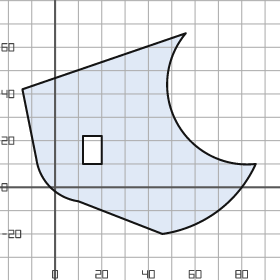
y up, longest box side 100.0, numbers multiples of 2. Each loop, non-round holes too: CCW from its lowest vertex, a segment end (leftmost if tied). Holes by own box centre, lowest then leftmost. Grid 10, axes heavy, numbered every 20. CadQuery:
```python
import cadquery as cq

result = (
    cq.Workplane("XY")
    .moveTo(46.0, -20.0)
    .threePointArc((70.0, -10.0), (86.0, 10.0))
    .threePointArc((52.0, 28.0), (56.0, 66.0))
    .lineTo(-14.0, 42.0)
    .lineTo(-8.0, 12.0)
    .threePointArc((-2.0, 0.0), (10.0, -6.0))
    .close()
    .moveTo(12.0, 10.0)
    .lineTo(20.0, 10.0)
    .lineTo(20.0, 22.0)
    .lineTo(12.0, 22.0)
    .close()
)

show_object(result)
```